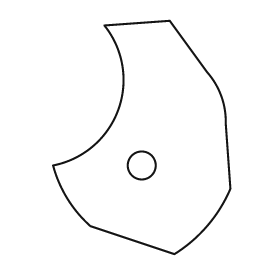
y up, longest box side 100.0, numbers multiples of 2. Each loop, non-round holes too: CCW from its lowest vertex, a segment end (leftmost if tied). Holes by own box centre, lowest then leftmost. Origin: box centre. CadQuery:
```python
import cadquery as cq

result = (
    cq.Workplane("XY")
    .moveTo(14.0, -50.0)
    .threePointArc((28.0, -38.0), (38.0, -22.0))
    .lineTo(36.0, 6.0)
    .threePointArc((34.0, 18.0), (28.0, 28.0))
    .lineTo(12.0, 50.0)
    .lineTo(-16.0, 48.0)
    .threePointArc((-10.0, 12.0), (-38.0, -12.0))
    .threePointArc((-32.0, -26.0), (-22.0, -38.0))
    .close()
    .moveTo(0.0, -12.0)
    .circle(6.0)
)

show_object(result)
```